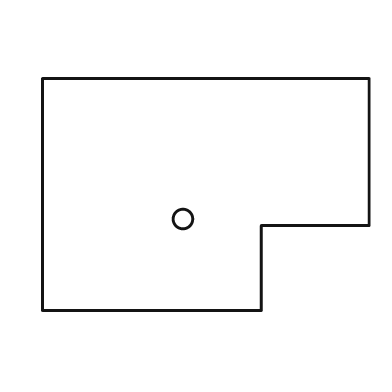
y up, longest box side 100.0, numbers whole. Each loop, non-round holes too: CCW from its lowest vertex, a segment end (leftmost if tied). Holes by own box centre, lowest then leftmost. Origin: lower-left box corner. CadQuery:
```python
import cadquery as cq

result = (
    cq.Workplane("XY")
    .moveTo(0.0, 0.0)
    .lineTo(67.0, 0.0)
    .lineTo(67.0, 26.0)
    .lineTo(100.0, 26.0)
    .lineTo(100.0, 71.0)
    .lineTo(0.0, 71.0)
    .close()
    .moveTo(43.0, 28.0)
    .circle(3.0)
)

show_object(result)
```